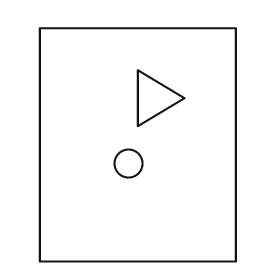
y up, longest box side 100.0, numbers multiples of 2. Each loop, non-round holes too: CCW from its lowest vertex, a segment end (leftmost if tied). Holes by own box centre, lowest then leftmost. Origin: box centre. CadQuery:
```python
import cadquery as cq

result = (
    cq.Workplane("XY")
    .moveTo(-42.0, -50.0)
    .lineTo(42.0, -50.0)
    .lineTo(42.0, 50.0)
    .lineTo(-42.0, 50.0)
    .close()
    .moveTo(-4.0, -8.0)
    .circle(6.0)
    .moveTo(0.0, 8.0)
    .lineTo(20.0, 20.0)
    .lineTo(0.0, 32.0)
    .close()
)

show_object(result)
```